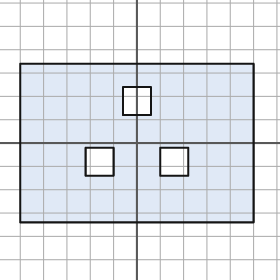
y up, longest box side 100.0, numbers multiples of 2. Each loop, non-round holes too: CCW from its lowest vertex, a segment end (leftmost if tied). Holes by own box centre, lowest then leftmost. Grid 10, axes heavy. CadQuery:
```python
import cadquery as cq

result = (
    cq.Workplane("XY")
    .moveTo(-50.0, -34.0)
    .lineTo(50.0, -34.0)
    .lineTo(50.0, 34.0)
    .lineTo(-50.0, 34.0)
    .close()
    .moveTo(-22.0, -14.0)
    .lineTo(-10.0, -14.0)
    .lineTo(-10.0, -2.0)
    .lineTo(-22.0, -2.0)
    .close()
    .moveTo(10.0, -14.0)
    .lineTo(22.0, -14.0)
    .lineTo(22.0, -2.0)
    .lineTo(10.0, -2.0)
    .close()
    .moveTo(-6.0, 12.0)
    .lineTo(6.0, 12.0)
    .lineTo(6.0, 24.0)
    .lineTo(-6.0, 24.0)
    .close()
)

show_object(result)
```